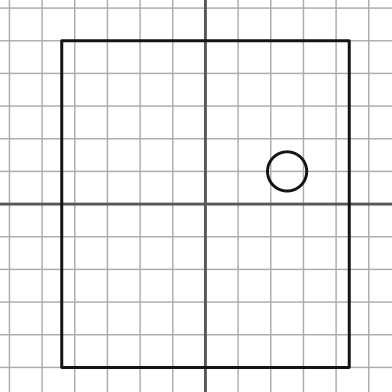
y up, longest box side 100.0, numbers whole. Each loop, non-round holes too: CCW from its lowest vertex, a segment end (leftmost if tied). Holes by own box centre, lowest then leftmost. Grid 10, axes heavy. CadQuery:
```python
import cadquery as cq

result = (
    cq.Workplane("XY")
    .moveTo(-44.0, -50.0)
    .lineTo(44.0, -50.0)
    .lineTo(44.0, 50.0)
    .lineTo(-44.0, 50.0)
    .close()
    .moveTo(25.0, 10.0)
    .circle(6.0)
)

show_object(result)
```